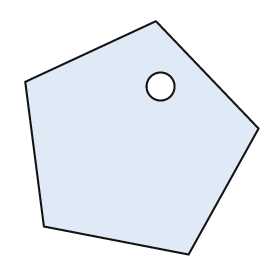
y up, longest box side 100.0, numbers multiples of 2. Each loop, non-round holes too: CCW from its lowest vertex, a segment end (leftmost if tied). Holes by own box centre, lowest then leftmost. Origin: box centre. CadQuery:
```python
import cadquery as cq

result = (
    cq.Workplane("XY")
    .moveTo(20.0, -50.0)
    .lineTo(50.0, 4.0)
    .lineTo(6.0, 50.0)
    .lineTo(-50.0, 24.0)
    .lineTo(-42.0, -38.0)
    .close()
    .moveTo(8.0, 22.0)
    .circle(6.0)
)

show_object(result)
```